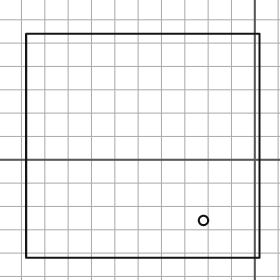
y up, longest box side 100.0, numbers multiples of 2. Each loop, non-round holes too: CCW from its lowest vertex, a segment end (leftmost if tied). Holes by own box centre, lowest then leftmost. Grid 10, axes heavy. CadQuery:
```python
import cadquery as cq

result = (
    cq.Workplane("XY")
    .moveTo(-98.0, -42.0)
    .lineTo(2.0, -42.0)
    .lineTo(2.0, 54.0)
    .lineTo(-98.0, 54.0)
    .close()
    .moveTo(-22.0, -26.0)
    .circle(2.0)
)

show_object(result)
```